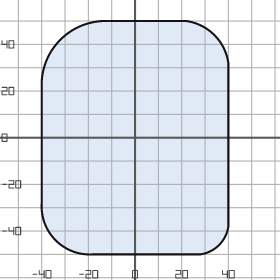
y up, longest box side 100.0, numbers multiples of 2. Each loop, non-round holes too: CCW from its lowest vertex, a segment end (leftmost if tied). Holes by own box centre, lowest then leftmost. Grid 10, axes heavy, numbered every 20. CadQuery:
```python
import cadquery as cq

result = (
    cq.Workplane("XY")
    .moveTo(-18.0, -50.0)
    .lineTo(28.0, -50.0)
    .threePointArc((36.0, -46.0), (40.0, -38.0))
    .lineTo(40.0, 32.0)
    .threePointArc((34.0, 44.0), (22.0, 50.0))
    .lineTo(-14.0, 50.0)
    .threePointArc((-32.0, 42.0), (-40.0, 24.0))
    .lineTo(-40.0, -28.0)
    .threePointArc((-34.0, -44.0), (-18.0, -50.0))
    .close()
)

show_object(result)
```